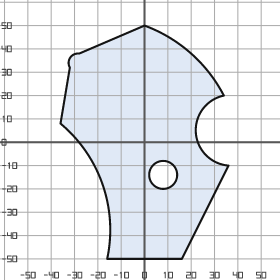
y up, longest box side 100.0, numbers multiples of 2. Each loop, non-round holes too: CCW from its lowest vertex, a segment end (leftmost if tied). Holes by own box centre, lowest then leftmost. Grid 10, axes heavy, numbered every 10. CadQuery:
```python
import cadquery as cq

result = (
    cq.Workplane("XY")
    .moveTo(-16.0, -50.0)
    .lineTo(16.0, -50.0)
    .lineTo(36.0, -10.0)
    .threePointArc((22.0, 4.0), (34.0, 20.0))
    .threePointArc((20.0, 38.0), (0.0, 50.0))
    .lineTo(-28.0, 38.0)
    .threePointArc((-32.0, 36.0), (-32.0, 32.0))
    .lineTo(-36.0, 8.0)
    .threePointArc((-18.0, -18.0), (-16.0, -50.0))
    .close()
    .moveTo(8.0, -14.0)
    .circle(6.0)
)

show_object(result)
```